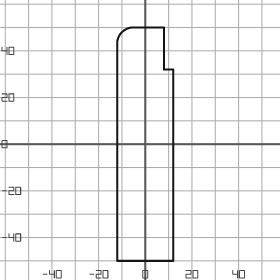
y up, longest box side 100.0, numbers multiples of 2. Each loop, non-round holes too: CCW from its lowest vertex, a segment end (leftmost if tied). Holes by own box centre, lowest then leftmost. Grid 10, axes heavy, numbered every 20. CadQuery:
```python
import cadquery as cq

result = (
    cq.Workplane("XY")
    .moveTo(-12.0, -50.0)
    .lineTo(12.0, -50.0)
    .lineTo(12.0, 32.0)
    .lineTo(8.0, 32.0)
    .lineTo(8.0, 50.0)
    .lineTo(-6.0, 50.0)
    .threePointArc((-10.0, 48.0), (-12.0, 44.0))
    .close()
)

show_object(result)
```